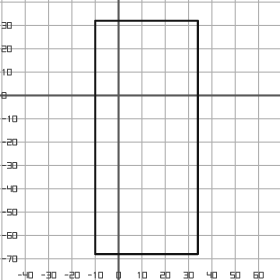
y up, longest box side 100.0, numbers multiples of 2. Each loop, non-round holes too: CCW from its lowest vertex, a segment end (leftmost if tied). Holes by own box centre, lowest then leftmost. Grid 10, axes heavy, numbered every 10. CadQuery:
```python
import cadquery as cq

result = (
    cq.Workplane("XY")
    .moveTo(-10.0, -68.0)
    .lineTo(34.0, -68.0)
    .lineTo(34.0, 32.0)
    .lineTo(-10.0, 32.0)
    .close()
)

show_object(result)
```